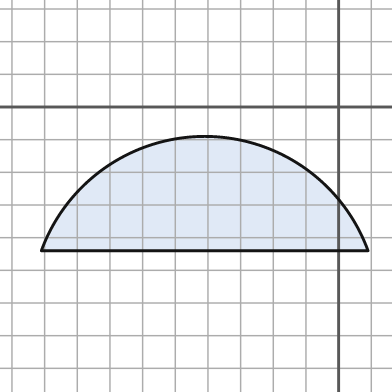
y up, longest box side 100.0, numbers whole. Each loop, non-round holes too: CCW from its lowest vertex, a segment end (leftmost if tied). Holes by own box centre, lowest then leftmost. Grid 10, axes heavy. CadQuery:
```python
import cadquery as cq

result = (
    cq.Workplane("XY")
    .moveTo(-91.0, -44.0)
    .lineTo(9.0, -44.0)
    .threePointArc((-41.0, -9.0), (-91.0, -44.0))
    .close()
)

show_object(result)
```